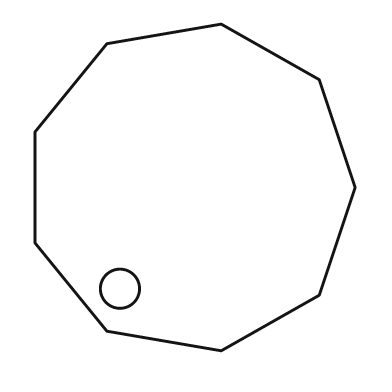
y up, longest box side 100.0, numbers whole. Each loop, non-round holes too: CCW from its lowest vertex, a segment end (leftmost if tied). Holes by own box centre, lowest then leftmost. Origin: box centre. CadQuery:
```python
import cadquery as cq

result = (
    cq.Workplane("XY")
    .moveTo(8.0, -50.0)
    .lineTo(38.0, -33.0)
    .lineTo(49.0, 0.0)
    .lineTo(38.0, 33.0)
    .lineTo(8.0, 50.0)
    .lineTo(-27.0, 44.0)
    .lineTo(-49.0, 17.0)
    .lineTo(-49.0, -17.0)
    .lineTo(-27.0, -44.0)
    .close()
    .moveTo(-23.0, -31.0)
    .circle(6.0)
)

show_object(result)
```